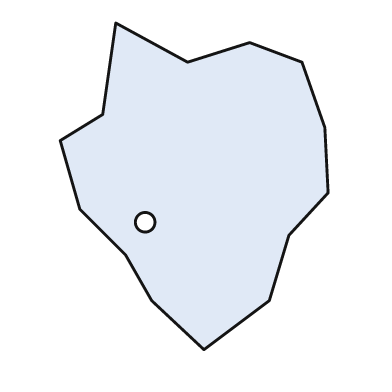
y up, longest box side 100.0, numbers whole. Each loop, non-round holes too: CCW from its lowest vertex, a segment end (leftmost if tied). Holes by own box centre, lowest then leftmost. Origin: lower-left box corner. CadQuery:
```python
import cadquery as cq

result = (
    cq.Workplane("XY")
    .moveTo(44.0, 0.0)
    .lineTo(64.0, 15.0)
    .lineTo(70.0, 35.0)
    .lineTo(82.0, 48.0)
    .lineTo(81.0, 68.0)
    .lineTo(74.0, 88.0)
    .lineTo(58.0, 94.0)
    .lineTo(39.0, 88.0)
    .lineTo(17.0, 100.0)
    .lineTo(13.0, 72.0)
    .lineTo(0.0, 64.0)
    .lineTo(6.0, 43.0)
    .lineTo(20.0, 29.0)
    .lineTo(28.0, 15.0)
    .close()
    .moveTo(26.0, 39.0)
    .circle(3.0)
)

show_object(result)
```